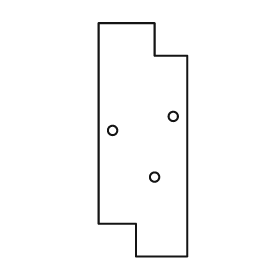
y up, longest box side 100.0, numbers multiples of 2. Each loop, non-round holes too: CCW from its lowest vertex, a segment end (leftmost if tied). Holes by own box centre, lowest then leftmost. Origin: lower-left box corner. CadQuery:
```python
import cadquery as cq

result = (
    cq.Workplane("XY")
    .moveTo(16.0, 0.0)
    .lineTo(38.0, 0.0)
    .lineTo(38.0, 86.0)
    .lineTo(24.0, 86.0)
    .lineTo(24.0, 100.0)
    .lineTo(0.0, 100.0)
    .lineTo(0.0, 14.0)
    .lineTo(16.0, 14.0)
    .close()
    .moveTo(24.0, 34.0)
    .circle(2.0)
    .moveTo(6.0, 54.0)
    .circle(2.0)
    .moveTo(32.0, 60.0)
    .circle(2.0)
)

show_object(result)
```